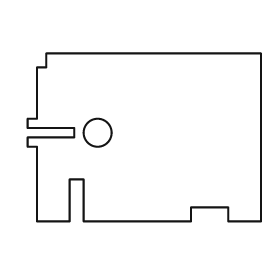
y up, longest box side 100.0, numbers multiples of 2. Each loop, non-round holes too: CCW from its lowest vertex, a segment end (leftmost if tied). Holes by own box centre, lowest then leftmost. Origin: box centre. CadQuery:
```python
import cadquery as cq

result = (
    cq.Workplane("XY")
    .moveTo(-46.0, -36.0)
    .lineTo(-32.0, -36.0)
    .lineTo(-32.0, -18.0)
    .lineTo(-26.0, -18.0)
    .lineTo(-26.0, -36.0)
    .lineTo(20.0, -36.0)
    .lineTo(20.0, -30.0)
    .lineTo(36.0, -30.0)
    .lineTo(36.0, -36.0)
    .lineTo(50.0, -36.0)
    .lineTo(50.0, 36.0)
    .lineTo(-42.0, 36.0)
    .lineTo(-42.0, 30.0)
    .lineTo(-46.0, 30.0)
    .lineTo(-46.0, 8.0)
    .lineTo(-50.0, 8.0)
    .lineTo(-50.0, 4.0)
    .lineTo(-30.0, 4.0)
    .lineTo(-30.0, 0.0)
    .lineTo(-50.0, 0.0)
    .lineTo(-50.0, -4.0)
    .lineTo(-46.0, -4.0)
    .close()
    .moveTo(-20.0, 2.0)
    .circle(6.0)
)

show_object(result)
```